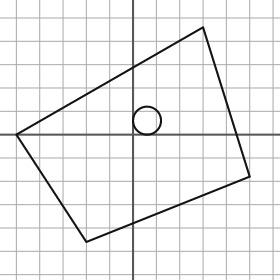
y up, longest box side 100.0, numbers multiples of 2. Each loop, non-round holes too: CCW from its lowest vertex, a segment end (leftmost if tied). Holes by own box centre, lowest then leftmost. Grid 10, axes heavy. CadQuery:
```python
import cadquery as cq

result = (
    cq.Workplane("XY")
    .moveTo(-20.0, -46.0)
    .lineTo(50.0, -18.0)
    .lineTo(30.0, 46.0)
    .lineTo(-50.0, 0.0)
    .close()
    .moveTo(6.0, 6.0)
    .circle(6.0)
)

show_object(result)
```